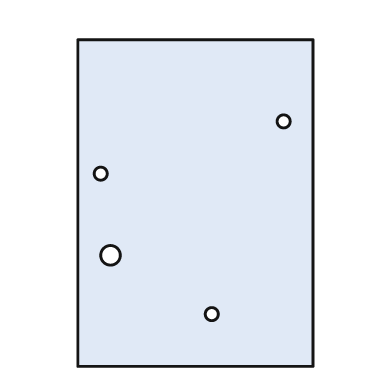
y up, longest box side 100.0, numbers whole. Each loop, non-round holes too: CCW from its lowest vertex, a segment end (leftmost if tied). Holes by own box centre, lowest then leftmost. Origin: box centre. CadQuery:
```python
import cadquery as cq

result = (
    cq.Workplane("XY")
    .moveTo(-36.0, -50.0)
    .lineTo(36.0, -50.0)
    .lineTo(36.0, 50.0)
    .lineTo(-36.0, 50.0)
    .close()
    .moveTo(5.0, -34.0)
    .circle(2.0)
    .moveTo(-26.0, -16.0)
    .circle(3.0)
    .moveTo(-29.0, 9.0)
    .circle(2.0)
    .moveTo(27.0, 25.0)
    .circle(2.0)
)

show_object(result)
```